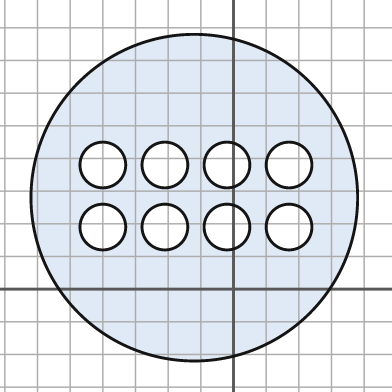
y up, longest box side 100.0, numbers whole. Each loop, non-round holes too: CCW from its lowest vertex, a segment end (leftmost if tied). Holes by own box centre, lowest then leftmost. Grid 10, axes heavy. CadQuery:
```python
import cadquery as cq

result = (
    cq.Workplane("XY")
    .moveTo(-12.0, 28.0)
    .circle(50.0)
    .moveTo(-40.0, 19.0)
    .circle(7.0)
    .moveTo(-21.0, 19.0)
    .circle(7.0)
    .moveTo(-2.0, 19.0)
    .circle(7.0)
    .moveTo(17.0, 19.0)
    .circle(7.0)
    .moveTo(-40.0, 38.0)
    .circle(7.0)
    .moveTo(-21.0, 38.0)
    .circle(7.0)
    .moveTo(-2.0, 38.0)
    .circle(7.0)
    .moveTo(17.0, 38.0)
    .circle(7.0)
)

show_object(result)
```